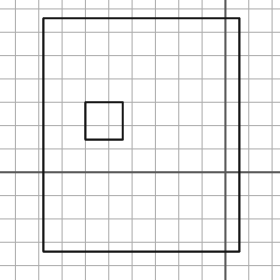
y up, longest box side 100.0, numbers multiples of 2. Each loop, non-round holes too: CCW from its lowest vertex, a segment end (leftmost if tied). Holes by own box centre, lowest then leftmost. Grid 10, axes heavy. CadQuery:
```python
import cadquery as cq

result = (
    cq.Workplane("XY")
    .moveTo(-78.0, -34.0)
    .lineTo(6.0, -34.0)
    .lineTo(6.0, 66.0)
    .lineTo(-78.0, 66.0)
    .close()
    .moveTo(-60.0, 14.0)
    .lineTo(-44.0, 14.0)
    .lineTo(-44.0, 30.0)
    .lineTo(-60.0, 30.0)
    .close()
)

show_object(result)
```